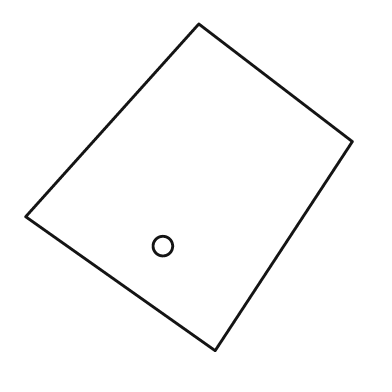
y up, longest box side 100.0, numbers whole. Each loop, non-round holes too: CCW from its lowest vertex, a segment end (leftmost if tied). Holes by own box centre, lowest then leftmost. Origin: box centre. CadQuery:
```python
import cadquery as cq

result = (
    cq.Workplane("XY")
    .moveTo(8.0, -50.0)
    .lineTo(50.0, 14.0)
    .lineTo(3.0, 50.0)
    .lineTo(-50.0, -9.0)
    .close()
    .moveTo(-8.0, -18.0)
    .circle(3.0)
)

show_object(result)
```